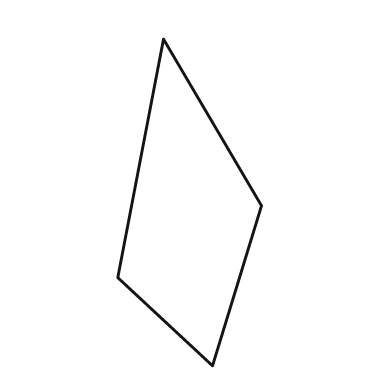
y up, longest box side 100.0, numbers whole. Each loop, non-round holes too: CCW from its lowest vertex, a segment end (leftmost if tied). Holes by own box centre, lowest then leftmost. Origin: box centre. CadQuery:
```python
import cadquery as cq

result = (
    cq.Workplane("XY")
    .moveTo(7.0, -50.0)
    .lineTo(22.0, -1.0)
    .lineTo(-8.0, 50.0)
    .lineTo(-22.0, -23.0)
    .close()
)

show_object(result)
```